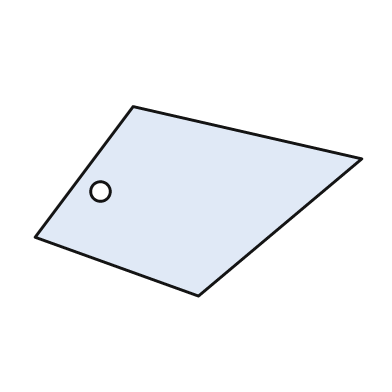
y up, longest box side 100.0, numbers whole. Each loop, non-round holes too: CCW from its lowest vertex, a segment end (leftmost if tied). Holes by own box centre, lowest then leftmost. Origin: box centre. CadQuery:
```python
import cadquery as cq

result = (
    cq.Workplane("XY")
    .moveTo(0.0, -29.0)
    .lineTo(50.0, 13.0)
    .lineTo(-20.0, 29.0)
    .lineTo(-50.0, -11.0)
    .close()
    .moveTo(-30.0, 3.0)
    .circle(3.0)
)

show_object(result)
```